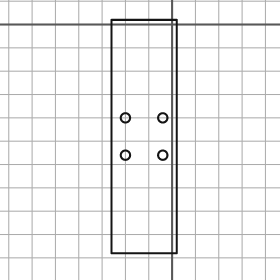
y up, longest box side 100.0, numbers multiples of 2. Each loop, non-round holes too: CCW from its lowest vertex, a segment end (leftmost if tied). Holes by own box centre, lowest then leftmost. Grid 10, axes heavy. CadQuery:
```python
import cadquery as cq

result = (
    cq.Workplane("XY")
    .moveTo(-26.0, -98.0)
    .lineTo(2.0, -98.0)
    .lineTo(2.0, 2.0)
    .lineTo(-26.0, 2.0)
    .close()
    .moveTo(-20.0, -56.0)
    .circle(2.0)
    .moveTo(-4.0, -56.0)
    .circle(2.0)
    .moveTo(-20.0, -40.0)
    .circle(2.0)
    .moveTo(-4.0, -40.0)
    .circle(2.0)
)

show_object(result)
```